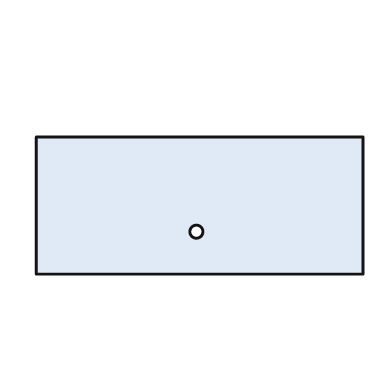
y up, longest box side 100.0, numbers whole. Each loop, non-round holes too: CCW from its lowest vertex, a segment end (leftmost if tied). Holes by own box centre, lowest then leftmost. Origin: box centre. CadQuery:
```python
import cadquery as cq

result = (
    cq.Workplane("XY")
    .moveTo(-50.0, -21.0)
    .lineTo(50.0, -21.0)
    .lineTo(50.0, 21.0)
    .lineTo(-50.0, 21.0)
    .close()
    .moveTo(-1.0, -8.0)
    .circle(2.0)
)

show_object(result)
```